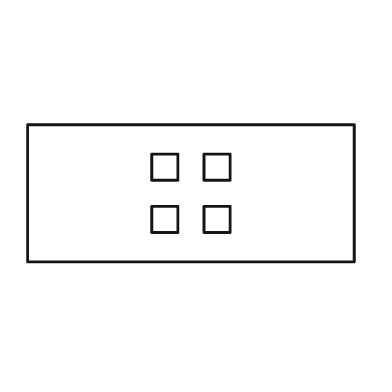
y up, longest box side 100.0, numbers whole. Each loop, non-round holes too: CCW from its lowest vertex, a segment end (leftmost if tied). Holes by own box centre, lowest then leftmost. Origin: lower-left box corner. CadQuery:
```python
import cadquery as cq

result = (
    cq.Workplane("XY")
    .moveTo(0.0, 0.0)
    .lineTo(100.0, 0.0)
    .lineTo(100.0, 42.0)
    .lineTo(0.0, 42.0)
    .close()
    .moveTo(38.0, 9.0)
    .lineTo(46.0, 9.0)
    .lineTo(46.0, 17.0)
    .lineTo(38.0, 17.0)
    .close()
    .moveTo(54.0, 9.0)
    .lineTo(62.0, 9.0)
    .lineTo(62.0, 17.0)
    .lineTo(54.0, 17.0)
    .close()
    .moveTo(38.0, 25.0)
    .lineTo(46.0, 25.0)
    .lineTo(46.0, 33.0)
    .lineTo(38.0, 33.0)
    .close()
    .moveTo(54.0, 25.0)
    .lineTo(62.0, 25.0)
    .lineTo(62.0, 33.0)
    .lineTo(54.0, 33.0)
    .close()
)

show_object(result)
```